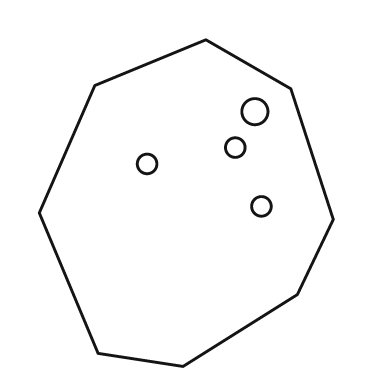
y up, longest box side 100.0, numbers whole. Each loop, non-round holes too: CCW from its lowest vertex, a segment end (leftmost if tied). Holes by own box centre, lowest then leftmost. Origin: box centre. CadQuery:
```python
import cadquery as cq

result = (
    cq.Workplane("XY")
    .moveTo(-1.0, -50.0)
    .lineTo(34.0, -28.0)
    .lineTo(45.0, -5.0)
    .lineTo(32.0, 35.0)
    .lineTo(6.0, 50.0)
    .lineTo(-28.0, 36.0)
    .lineTo(-45.0, -3.0)
    .lineTo(-27.0, -46.0)
    .close()
    .moveTo(23.0, -1.0)
    .circle(3.0)
    .moveTo(-12.0, 12.0)
    .circle(3.0)
    .moveTo(15.0, 17.0)
    .circle(3.0)
    .moveTo(21.0, 28.0)
    .circle(4.0)
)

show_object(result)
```